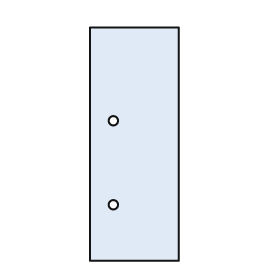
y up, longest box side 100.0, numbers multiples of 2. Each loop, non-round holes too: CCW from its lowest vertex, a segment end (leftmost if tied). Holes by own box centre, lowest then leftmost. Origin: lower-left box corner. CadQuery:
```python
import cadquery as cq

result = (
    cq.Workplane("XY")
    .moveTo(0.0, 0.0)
    .lineTo(38.0, 0.0)
    .lineTo(38.0, 100.0)
    .lineTo(0.0, 100.0)
    .close()
    .moveTo(10.0, 24.0)
    .circle(2.0)
    .moveTo(10.0, 60.0)
    .circle(2.0)
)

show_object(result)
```